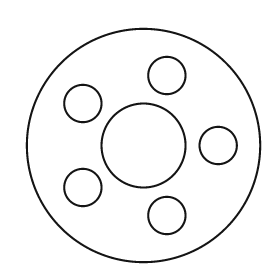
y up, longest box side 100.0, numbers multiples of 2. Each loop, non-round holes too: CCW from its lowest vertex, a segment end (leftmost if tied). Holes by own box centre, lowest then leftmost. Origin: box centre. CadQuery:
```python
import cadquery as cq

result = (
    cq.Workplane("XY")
    .moveTo(0.0, 0.0)
    .circle(50.0)
    .moveTo(10.0, -30.0)
    .circle(8.0)
    .moveTo(-26.0, -18.0)
    .circle(8.0)
    .moveTo(0.0, 0.0)
    .circle(18.0)
    .moveTo(32.0, 0.0)
    .circle(8.0)
    .moveTo(-26.0, 18.0)
    .circle(8.0)
    .moveTo(10.0, 30.0)
    .circle(8.0)
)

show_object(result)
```